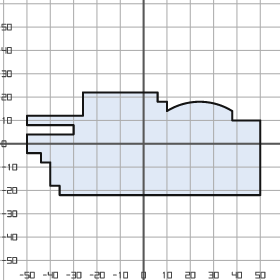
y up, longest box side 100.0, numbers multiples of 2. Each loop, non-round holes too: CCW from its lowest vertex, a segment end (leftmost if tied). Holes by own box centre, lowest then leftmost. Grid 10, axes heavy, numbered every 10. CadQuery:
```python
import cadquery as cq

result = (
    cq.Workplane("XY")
    .moveTo(-36.0, -22.0)
    .lineTo(50.0, -22.0)
    .lineTo(50.0, 10.0)
    .lineTo(38.0, 10.0)
    .lineTo(38.0, 14.0)
    .threePointArc((24.0, 18.0), (10.0, 14.0))
    .lineTo(10.0, 18.0)
    .lineTo(6.0, 18.0)
    .lineTo(6.0, 22.0)
    .lineTo(-26.0, 22.0)
    .lineTo(-26.0, 12.0)
    .lineTo(-50.0, 12.0)
    .lineTo(-50.0, 8.0)
    .lineTo(-30.0, 8.0)
    .lineTo(-30.0, 4.0)
    .lineTo(-50.0, 4.0)
    .lineTo(-50.0, -4.0)
    .lineTo(-44.0, -4.0)
    .lineTo(-44.0, -8.0)
    .lineTo(-40.0, -8.0)
    .lineTo(-40.0, -18.0)
    .lineTo(-36.0, -18.0)
    .close()
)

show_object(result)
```